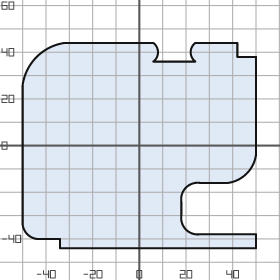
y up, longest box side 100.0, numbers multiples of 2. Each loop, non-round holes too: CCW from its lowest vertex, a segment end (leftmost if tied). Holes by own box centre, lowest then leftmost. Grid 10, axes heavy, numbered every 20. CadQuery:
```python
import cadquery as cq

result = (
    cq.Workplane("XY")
    .moveTo(-34.0, -44.0)
    .lineTo(50.0, -44.0)
    .lineTo(50.0, -38.0)
    .lineTo(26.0, -38.0)
    .threePointArc((20.0, -36.0), (18.0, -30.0))
    .lineTo(18.0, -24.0)
    .threePointArc((20.0, -18.0), (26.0, -16.0))
    .lineTo(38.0, -16.0)
    .threePointArc((46.0, -12.0), (50.0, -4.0))
    .lineTo(50.0, 38.0)
    .lineTo(42.0, 38.0)
    .lineTo(42.0, 44.0)
    .lineTo(24.0, 44.0)
    .threePointArc((22.0, 40.0), (24.0, 36.0))
    .lineTo(6.0, 36.0)
    .threePointArc((8.0, 40.0), (6.0, 44.0))
    .lineTo(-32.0, 44.0)
    .threePointArc((-44.0, 38.0), (-50.0, 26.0))
    .lineTo(-50.0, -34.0)
    .threePointArc((-48.0, -38.0), (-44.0, -40.0))
    .lineTo(-34.0, -40.0)
    .close()
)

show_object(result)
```